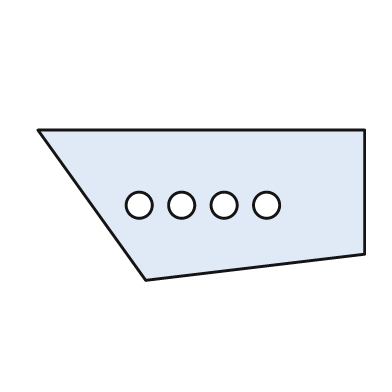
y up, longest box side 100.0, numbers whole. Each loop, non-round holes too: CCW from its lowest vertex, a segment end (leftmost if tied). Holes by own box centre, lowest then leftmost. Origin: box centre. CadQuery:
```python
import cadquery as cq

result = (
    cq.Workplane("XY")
    .moveTo(-17.0, -23.0)
    .lineTo(50.0, -15.0)
    .lineTo(50.0, 23.0)
    .lineTo(-50.0, 23.0)
    .close()
    .moveTo(-19.0, 0.0)
    .circle(4.0)
    .moveTo(-6.0, 0.0)
    .circle(4.0)
    .moveTo(7.0, 0.0)
    .circle(4.0)
    .moveTo(20.0, 0.0)
    .circle(4.0)
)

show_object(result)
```